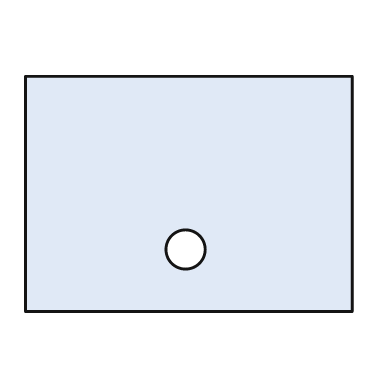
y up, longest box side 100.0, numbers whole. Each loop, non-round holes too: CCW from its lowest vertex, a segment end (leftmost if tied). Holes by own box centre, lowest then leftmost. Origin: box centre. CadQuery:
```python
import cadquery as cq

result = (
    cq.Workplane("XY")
    .moveTo(-50.0, -36.0)
    .lineTo(50.0, -36.0)
    .lineTo(50.0, 36.0)
    .lineTo(-50.0, 36.0)
    .close()
    .moveTo(-1.0, -17.0)
    .circle(6.0)
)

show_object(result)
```